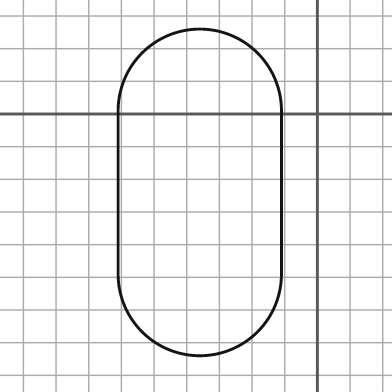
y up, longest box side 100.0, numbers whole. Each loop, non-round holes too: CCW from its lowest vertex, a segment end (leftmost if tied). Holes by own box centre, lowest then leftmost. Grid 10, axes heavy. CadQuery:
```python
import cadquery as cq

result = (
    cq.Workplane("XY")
    .moveTo(-61.0, -49.0)
    .threePointArc((-36.0, -74.0), (-11.0, -49.0))
    .lineTo(-11.0, 1.0)
    .threePointArc((-36.0, 26.0), (-61.0, 1.0))
    .close()
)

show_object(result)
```